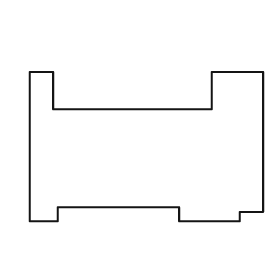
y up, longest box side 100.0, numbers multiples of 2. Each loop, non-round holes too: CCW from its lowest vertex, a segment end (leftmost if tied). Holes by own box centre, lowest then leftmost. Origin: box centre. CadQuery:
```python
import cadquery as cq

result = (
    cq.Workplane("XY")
    .moveTo(-50.0, -32.0)
    .lineTo(-38.0, -32.0)
    .lineTo(-38.0, -26.0)
    .lineTo(14.0, -26.0)
    .lineTo(14.0, -32.0)
    .lineTo(40.0, -32.0)
    .lineTo(40.0, -28.0)
    .lineTo(50.0, -28.0)
    .lineTo(50.0, 32.0)
    .lineTo(28.0, 32.0)
    .lineTo(28.0, 16.0)
    .lineTo(-40.0, 16.0)
    .lineTo(-40.0, 32.0)
    .lineTo(-50.0, 32.0)
    .close()
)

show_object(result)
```